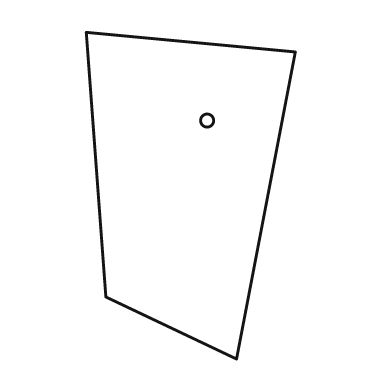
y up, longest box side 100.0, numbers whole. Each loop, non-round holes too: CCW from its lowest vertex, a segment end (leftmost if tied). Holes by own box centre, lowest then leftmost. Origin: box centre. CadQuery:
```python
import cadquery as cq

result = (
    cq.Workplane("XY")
    .moveTo(14.0, -50.0)
    .lineTo(32.0, 44.0)
    .lineTo(-32.0, 50.0)
    .lineTo(-26.0, -31.0)
    .close()
    .moveTo(5.0, 23.0)
    .circle(2.0)
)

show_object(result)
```